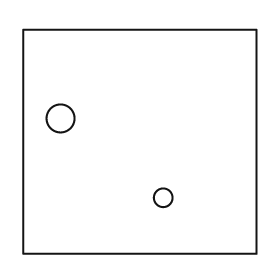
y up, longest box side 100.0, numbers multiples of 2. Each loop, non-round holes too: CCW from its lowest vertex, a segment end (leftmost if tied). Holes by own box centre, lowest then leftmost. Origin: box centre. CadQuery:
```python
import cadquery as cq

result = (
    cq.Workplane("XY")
    .moveTo(-50.0, -48.0)
    .lineTo(50.0, -48.0)
    .lineTo(50.0, 48.0)
    .lineTo(-50.0, 48.0)
    .close()
    .moveTo(10.0, -24.0)
    .circle(4.0)
    .moveTo(-34.0, 10.0)
    .circle(6.0)
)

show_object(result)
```